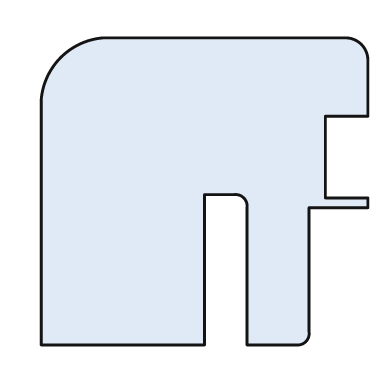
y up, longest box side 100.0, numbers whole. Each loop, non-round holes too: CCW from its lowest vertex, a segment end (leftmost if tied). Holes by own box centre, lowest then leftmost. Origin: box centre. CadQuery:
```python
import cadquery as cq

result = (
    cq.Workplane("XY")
    .moveTo(-50.0, -47.0)
    .lineTo(0.0, -47.0)
    .lineTo(0.0, -1.0)
    .lineTo(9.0, -1.0)
    .threePointArc((12.0, -2.0), (13.0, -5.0))
    .lineTo(13.0, -47.0)
    .lineTo(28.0, -47.0)
    .threePointArc((31.0, -46.0), (32.0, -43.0))
    .lineTo(32.0, -5.0)
    .lineTo(50.0, -5.0)
    .lineTo(50.0, -2.0)
    .lineTo(37.0, -2.0)
    .lineTo(37.0, 23.0)
    .lineTo(50.0, 23.0)
    .lineTo(50.0, 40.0)
    .threePointArc((48.0, 45.0), (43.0, 47.0))
    .lineTo(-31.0, 47.0)
    .threePointArc((-44.0, 41.0), (-50.0, 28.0))
    .close()
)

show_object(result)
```